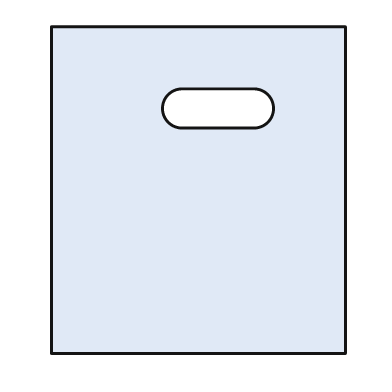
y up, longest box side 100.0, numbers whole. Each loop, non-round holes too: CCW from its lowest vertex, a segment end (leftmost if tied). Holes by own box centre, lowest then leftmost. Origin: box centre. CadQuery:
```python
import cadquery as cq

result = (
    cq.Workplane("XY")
    .moveTo(-45.0, -50.0)
    .lineTo(45.0, -50.0)
    .lineTo(45.0, 50.0)
    .lineTo(-45.0, 50.0)
    .close()
    .moveTo(-5.0, 19.0)
    .lineTo(17.0, 19.0)
    .threePointArc((23.0, 25.0), (17.0, 31.0))
    .lineTo(-5.0, 31.0)
    .threePointArc((-11.0, 25.0), (-5.0, 19.0))
    .close()
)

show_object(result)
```